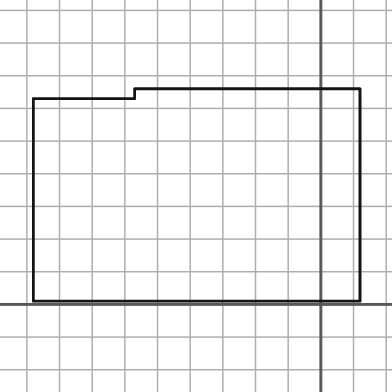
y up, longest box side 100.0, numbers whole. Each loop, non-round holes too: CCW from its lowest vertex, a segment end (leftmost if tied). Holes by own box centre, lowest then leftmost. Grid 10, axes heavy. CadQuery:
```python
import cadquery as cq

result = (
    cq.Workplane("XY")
    .moveTo(-88.0, 1.0)
    .lineTo(12.0, 1.0)
    .lineTo(12.0, 66.0)
    .lineTo(-57.0, 66.0)
    .lineTo(-57.0, 63.0)
    .lineTo(-88.0, 63.0)
    .close()
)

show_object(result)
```